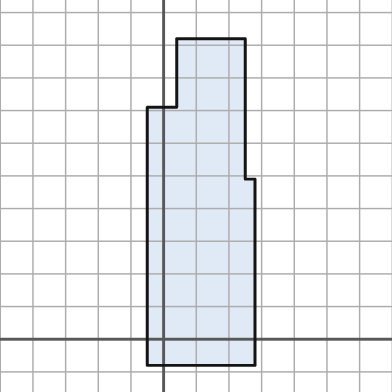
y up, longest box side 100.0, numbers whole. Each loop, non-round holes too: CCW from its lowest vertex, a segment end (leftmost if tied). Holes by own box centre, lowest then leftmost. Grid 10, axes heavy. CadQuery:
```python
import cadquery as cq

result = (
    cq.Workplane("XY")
    .moveTo(-5.0, -8.0)
    .lineTo(28.0, -8.0)
    .lineTo(28.0, 49.0)
    .lineTo(25.0, 49.0)
    .lineTo(25.0, 92.0)
    .lineTo(4.0, 92.0)
    .lineTo(4.0, 71.0)
    .lineTo(-5.0, 71.0)
    .close()
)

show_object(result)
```